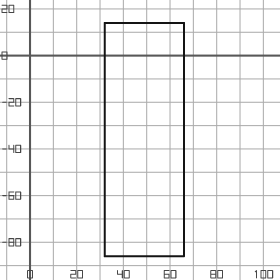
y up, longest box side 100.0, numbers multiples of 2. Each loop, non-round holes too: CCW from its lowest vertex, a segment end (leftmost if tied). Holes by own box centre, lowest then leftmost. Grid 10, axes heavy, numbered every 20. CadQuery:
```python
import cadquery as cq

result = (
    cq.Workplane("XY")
    .moveTo(32.0, -86.0)
    .lineTo(66.0, -86.0)
    .lineTo(66.0, 14.0)
    .lineTo(32.0, 14.0)
    .close()
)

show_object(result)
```